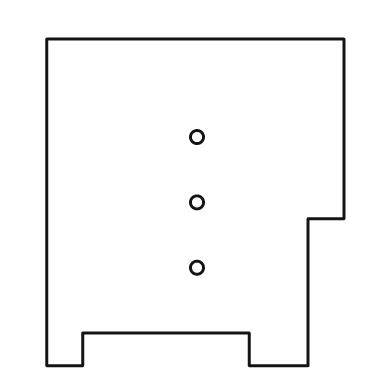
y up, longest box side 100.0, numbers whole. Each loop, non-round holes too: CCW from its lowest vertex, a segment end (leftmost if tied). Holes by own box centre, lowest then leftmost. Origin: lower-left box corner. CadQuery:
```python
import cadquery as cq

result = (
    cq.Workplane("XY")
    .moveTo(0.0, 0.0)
    .lineTo(11.0, 0.0)
    .lineTo(11.0, 10.0)
    .lineTo(62.0, 10.0)
    .lineTo(62.0, 0.0)
    .lineTo(80.0, 0.0)
    .lineTo(80.0, 45.0)
    .lineTo(91.0, 45.0)
    .lineTo(91.0, 100.0)
    .lineTo(0.0, 100.0)
    .close()
    .moveTo(46.0, 30.0)
    .circle(2.0)
    .moveTo(46.0, 50.0)
    .circle(2.0)
    .moveTo(46.0, 70.0)
    .circle(2.0)
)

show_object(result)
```